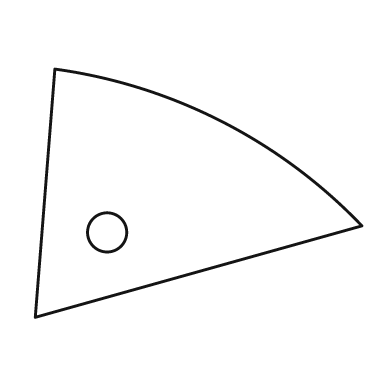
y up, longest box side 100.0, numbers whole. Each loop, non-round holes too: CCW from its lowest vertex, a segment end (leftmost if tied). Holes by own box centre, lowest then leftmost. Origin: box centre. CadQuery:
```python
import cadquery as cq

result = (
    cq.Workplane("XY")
    .moveTo(-50.0, -38.0)
    .lineTo(50.0, -10.0)
    .threePointArc((7.0, 22.0), (-44.0, 38.0))
    .close()
    .moveTo(-28.0, -12.0)
    .circle(6.0)
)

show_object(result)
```